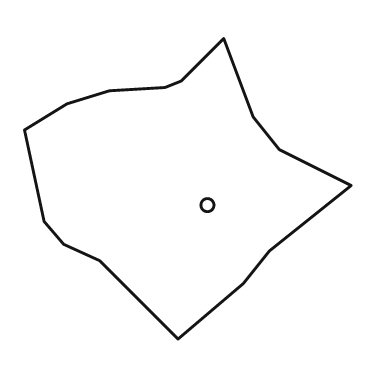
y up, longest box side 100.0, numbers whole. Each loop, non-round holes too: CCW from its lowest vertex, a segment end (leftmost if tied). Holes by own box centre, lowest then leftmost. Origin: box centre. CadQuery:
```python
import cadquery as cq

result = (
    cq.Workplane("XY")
    .moveTo(-3.0, -46.0)
    .lineTo(17.0, -29.0)
    .lineTo(25.0, -19.0)
    .lineTo(50.0, 1.0)
    .lineTo(28.0, 12.0)
    .lineTo(20.0, 22.0)
    .lineTo(11.0, 46.0)
    .lineTo(-2.0, 33.0)
    .lineTo(-7.0, 31.0)
    .lineTo(-24.0, 30.0)
    .lineTo(-37.0, 26.0)
    .lineTo(-50.0, 18.0)
    .lineTo(-44.0, -10.0)
    .lineTo(-38.0, -17.0)
    .lineTo(-27.0, -22.0)
    .close()
    .moveTo(6.0, -5.0)
    .circle(2.0)
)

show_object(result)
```